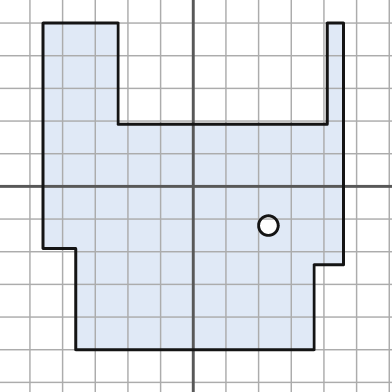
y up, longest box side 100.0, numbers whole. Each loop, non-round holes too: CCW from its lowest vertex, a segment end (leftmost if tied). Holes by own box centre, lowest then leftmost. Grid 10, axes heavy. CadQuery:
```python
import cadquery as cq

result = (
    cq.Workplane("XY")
    .moveTo(-36.0, -50.0)
    .lineTo(37.0, -50.0)
    .lineTo(37.0, -24.0)
    .lineTo(46.0, -24.0)
    .lineTo(46.0, 50.0)
    .lineTo(41.0, 50.0)
    .lineTo(41.0, 19.0)
    .lineTo(-23.0, 19.0)
    .lineTo(-23.0, 50.0)
    .lineTo(-46.0, 50.0)
    .lineTo(-46.0, -19.0)
    .lineTo(-36.0, -19.0)
    .close()
    .moveTo(23.0, -12.0)
    .circle(3.0)
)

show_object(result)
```